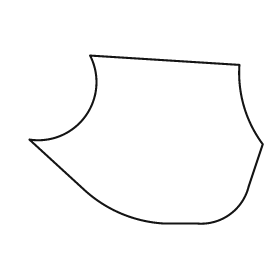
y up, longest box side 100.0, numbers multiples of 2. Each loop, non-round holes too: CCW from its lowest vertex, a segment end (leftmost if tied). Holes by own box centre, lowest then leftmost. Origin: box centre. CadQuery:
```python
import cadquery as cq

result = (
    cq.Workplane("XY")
    .moveTo(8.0, -36.0)
    .lineTo(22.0, -36.0)
    .threePointArc((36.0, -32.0), (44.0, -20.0))
    .lineTo(50.0, -2.0)
    .threePointArc((42.0, 14.0), (40.0, 32.0))
    .lineTo(-24.0, 36.0)
    .threePointArc((-26.0, 10.0), (-50.0, 0.0))
    .lineTo(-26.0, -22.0)
    .threePointArc((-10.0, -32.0), (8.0, -36.0))
    .close()
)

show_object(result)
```